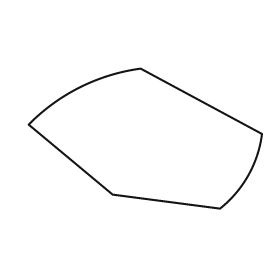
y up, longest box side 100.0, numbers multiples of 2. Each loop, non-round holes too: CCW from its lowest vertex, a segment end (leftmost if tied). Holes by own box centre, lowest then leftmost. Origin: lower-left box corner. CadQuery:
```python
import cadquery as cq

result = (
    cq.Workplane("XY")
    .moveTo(82.0, 0.0)
    .threePointArc((94.0, 14.0), (100.0, 32.0))
    .lineTo(48.0, 60.0)
    .threePointArc((22.0, 52.0), (0.0, 36.0))
    .lineTo(36.0, 6.0)
    .close()
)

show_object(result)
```